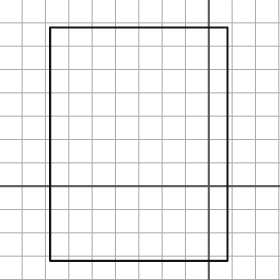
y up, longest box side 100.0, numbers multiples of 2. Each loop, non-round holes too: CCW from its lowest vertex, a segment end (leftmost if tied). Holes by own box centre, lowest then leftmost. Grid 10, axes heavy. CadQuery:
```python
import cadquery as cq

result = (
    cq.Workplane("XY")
    .moveTo(-68.0, -32.0)
    .lineTo(8.0, -32.0)
    .lineTo(8.0, 68.0)
    .lineTo(-68.0, 68.0)
    .close()
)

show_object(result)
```